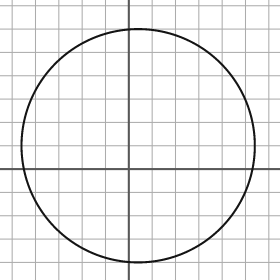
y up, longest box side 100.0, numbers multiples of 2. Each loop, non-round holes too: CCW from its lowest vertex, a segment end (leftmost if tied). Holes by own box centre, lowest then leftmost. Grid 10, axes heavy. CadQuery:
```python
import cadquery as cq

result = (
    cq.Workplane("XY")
    .moveTo(4.0, 10.0)
    .circle(50.0)
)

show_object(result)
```